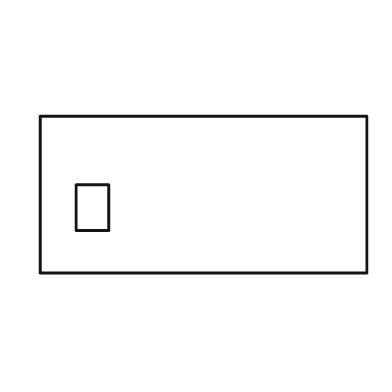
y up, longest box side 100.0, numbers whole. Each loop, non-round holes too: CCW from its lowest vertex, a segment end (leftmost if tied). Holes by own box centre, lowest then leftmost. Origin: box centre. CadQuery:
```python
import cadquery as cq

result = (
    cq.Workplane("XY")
    .moveTo(-50.0, -24.0)
    .lineTo(50.0, -24.0)
    .lineTo(50.0, 24.0)
    .lineTo(-50.0, 24.0)
    .close()
    .moveTo(-39.0, -11.0)
    .lineTo(-29.0, -11.0)
    .lineTo(-29.0, 3.0)
    .lineTo(-39.0, 3.0)
    .close()
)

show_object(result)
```